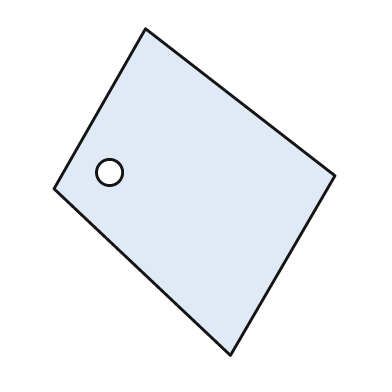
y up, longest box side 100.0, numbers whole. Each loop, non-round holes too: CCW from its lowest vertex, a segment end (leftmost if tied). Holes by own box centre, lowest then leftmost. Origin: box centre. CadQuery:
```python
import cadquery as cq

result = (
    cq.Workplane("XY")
    .moveTo(11.0, -50.0)
    .lineTo(43.0, 5.0)
    .lineTo(-15.0, 50.0)
    .lineTo(-43.0, 1.0)
    .close()
    .moveTo(-26.0, 6.0)
    .circle(4.0)
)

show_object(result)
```